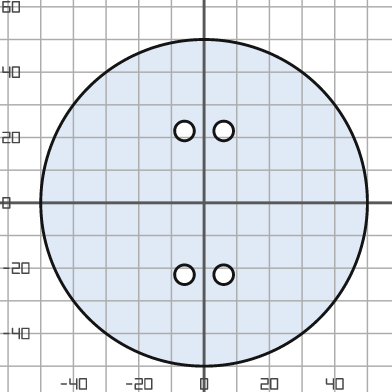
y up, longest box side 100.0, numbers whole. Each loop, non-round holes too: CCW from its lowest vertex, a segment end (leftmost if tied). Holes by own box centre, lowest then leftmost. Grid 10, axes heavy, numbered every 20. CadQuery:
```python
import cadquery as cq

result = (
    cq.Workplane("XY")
    .moveTo(0.0, 0.0)
    .circle(50.0)
    .moveTo(-6.0, -22.0)
    .circle(3.0)
    .moveTo(6.0, -22.0)
    .circle(3.0)
    .moveTo(-6.0, 22.0)
    .circle(3.0)
    .moveTo(6.0, 22.0)
    .circle(3.0)
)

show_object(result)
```